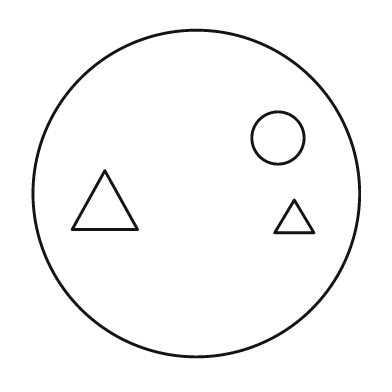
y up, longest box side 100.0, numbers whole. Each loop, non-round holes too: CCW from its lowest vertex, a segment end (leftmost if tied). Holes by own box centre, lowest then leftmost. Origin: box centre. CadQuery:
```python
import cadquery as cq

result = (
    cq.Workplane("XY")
    .moveTo(0.0, 0.0)
    .circle(50.0)
    .moveTo(24.0, -12.0)
    .lineTo(36.0, -12.0)
    .lineTo(30.0, -2.0)
    .close()
    .moveTo(-38.0, -11.0)
    .lineTo(-18.0, -11.0)
    .lineTo(-28.0, 7.0)
    .close()
    .moveTo(25.0, 17.0)
    .circle(8.0)
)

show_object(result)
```